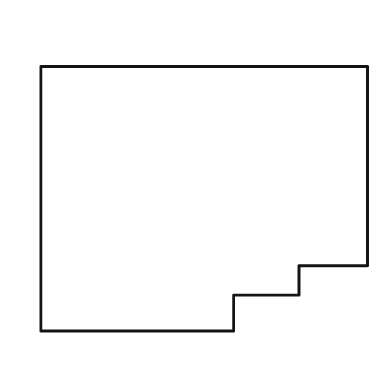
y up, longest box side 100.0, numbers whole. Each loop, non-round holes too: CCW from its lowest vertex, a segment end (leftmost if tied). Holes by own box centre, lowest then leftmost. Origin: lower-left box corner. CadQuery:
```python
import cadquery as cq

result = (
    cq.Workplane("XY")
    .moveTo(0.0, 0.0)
    .lineTo(59.0, 0.0)
    .lineTo(59.0, 11.0)
    .lineTo(79.0, 11.0)
    .lineTo(79.0, 20.0)
    .lineTo(100.0, 20.0)
    .lineTo(100.0, 81.0)
    .lineTo(0.0, 81.0)
    .close()
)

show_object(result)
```